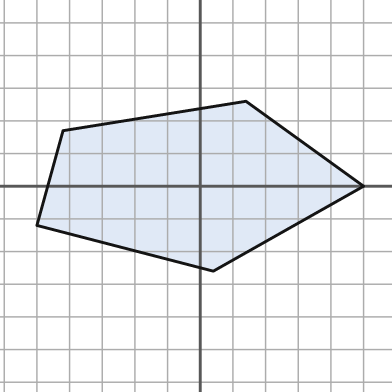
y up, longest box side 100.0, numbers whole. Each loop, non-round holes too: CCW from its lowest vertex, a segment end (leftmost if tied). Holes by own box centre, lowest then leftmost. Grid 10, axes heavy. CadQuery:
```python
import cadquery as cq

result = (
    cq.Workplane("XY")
    .moveTo(4.0, -26.0)
    .lineTo(50.0, 0.0)
    .lineTo(14.0, 26.0)
    .lineTo(-42.0, 17.0)
    .lineTo(-50.0, -12.0)
    .close()
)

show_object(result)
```